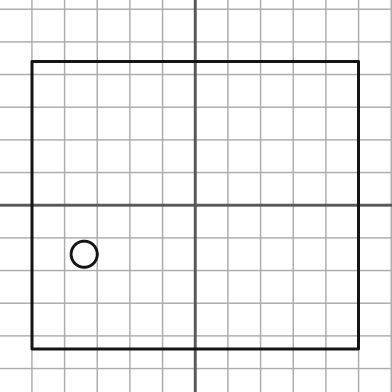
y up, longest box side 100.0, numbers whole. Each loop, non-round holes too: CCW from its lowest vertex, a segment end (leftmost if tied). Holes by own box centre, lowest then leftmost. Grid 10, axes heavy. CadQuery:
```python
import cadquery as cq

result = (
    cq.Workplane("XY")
    .moveTo(-50.0, -44.0)
    .lineTo(50.0, -44.0)
    .lineTo(50.0, 44.0)
    .lineTo(-50.0, 44.0)
    .close()
    .moveTo(-34.0, -15.0)
    .circle(4.0)
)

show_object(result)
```